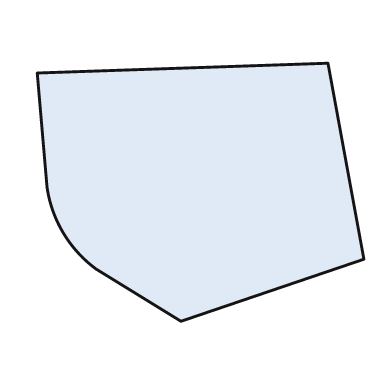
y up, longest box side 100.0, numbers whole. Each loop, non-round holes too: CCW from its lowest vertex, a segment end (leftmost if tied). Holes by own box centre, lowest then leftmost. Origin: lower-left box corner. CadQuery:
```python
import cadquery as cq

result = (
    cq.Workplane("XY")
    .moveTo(44.0, 0.0)
    .lineTo(100.0, 19.0)
    .lineTo(89.0, 79.0)
    .lineTo(0.0, 76.0)
    .lineTo(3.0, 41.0)
    .threePointArc((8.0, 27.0), (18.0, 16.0))
    .close()
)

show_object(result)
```